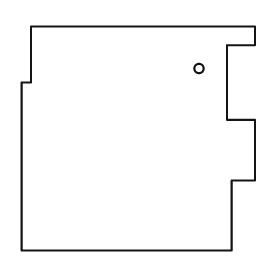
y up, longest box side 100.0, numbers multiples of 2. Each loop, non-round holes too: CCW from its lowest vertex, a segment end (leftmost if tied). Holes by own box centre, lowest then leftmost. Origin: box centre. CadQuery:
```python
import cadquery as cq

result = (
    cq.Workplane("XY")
    .moveTo(-50.0, -48.0)
    .lineTo(40.0, -48.0)
    .lineTo(40.0, -18.0)
    .lineTo(50.0, -18.0)
    .lineTo(50.0, 8.0)
    .lineTo(38.0, 8.0)
    .lineTo(38.0, 40.0)
    .lineTo(50.0, 40.0)
    .lineTo(50.0, 48.0)
    .lineTo(-46.0, 48.0)
    .lineTo(-46.0, 24.0)
    .lineTo(-50.0, 24.0)
    .close()
    .moveTo(26.0, 30.0)
    .circle(2.0)
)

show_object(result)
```